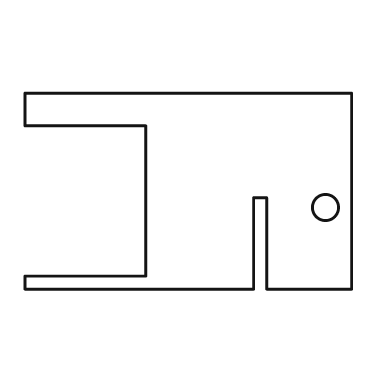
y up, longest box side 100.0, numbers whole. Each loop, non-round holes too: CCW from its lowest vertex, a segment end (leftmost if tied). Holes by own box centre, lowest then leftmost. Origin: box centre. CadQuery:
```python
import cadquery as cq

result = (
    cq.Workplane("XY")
    .moveTo(-50.0, -30.0)
    .lineTo(20.0, -30.0)
    .lineTo(20.0, -2.0)
    .lineTo(24.0, -2.0)
    .lineTo(24.0, -30.0)
    .lineTo(50.0, -30.0)
    .lineTo(50.0, 30.0)
    .lineTo(-50.0, 30.0)
    .lineTo(-50.0, 20.0)
    .lineTo(-13.0, 20.0)
    .lineTo(-13.0, -26.0)
    .lineTo(-50.0, -26.0)
    .close()
    .moveTo(42.0, -5.0)
    .circle(4.0)
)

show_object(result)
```